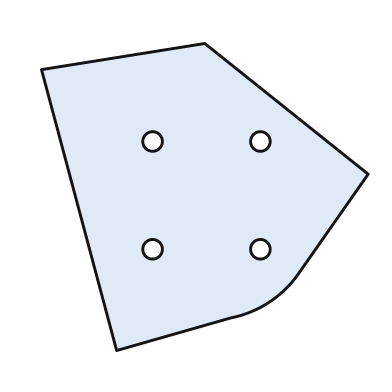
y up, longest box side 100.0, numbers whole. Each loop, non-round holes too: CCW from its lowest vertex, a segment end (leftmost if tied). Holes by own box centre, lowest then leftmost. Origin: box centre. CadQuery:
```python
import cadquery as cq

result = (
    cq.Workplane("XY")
    .moveTo(-27.0, -47.0)
    .lineTo(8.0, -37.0)
    .threePointArc((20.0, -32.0), (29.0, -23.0))
    .lineTo(50.0, 7.0)
    .lineTo(0.0, 47.0)
    .lineTo(-50.0, 39.0)
    .close()
    .moveTo(-16.0, -16.0)
    .circle(3.0)
    .moveTo(17.0, -16.0)
    .circle(3.0)
    .moveTo(-16.0, 17.0)
    .circle(3.0)
    .moveTo(17.0, 17.0)
    .circle(3.0)
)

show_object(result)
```